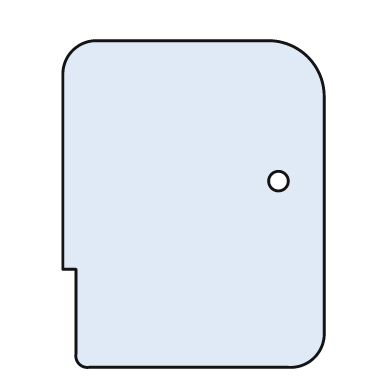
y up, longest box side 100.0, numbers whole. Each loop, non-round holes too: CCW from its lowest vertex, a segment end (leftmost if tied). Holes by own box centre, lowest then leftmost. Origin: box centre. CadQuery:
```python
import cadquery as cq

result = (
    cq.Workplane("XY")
    .moveTo(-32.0, -50.0)
    .lineTo(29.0, -50.0)
    .threePointArc((37.0, -47.0), (40.0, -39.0))
    .lineTo(40.0, 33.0)
    .threePointArc((35.0, 45.0), (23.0, 50.0))
    .lineTo(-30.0, 50.0)
    .threePointArc((-37.0, 47.0), (-40.0, 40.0))
    .lineTo(-40.0, -20.0)
    .lineTo(-36.0, -20.0)
    .lineTo(-36.0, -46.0)
    .threePointArc((-35.0, -49.0), (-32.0, -50.0))
    .close()
    .moveTo(26.0, 7.0)
    .circle(3.0)
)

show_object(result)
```